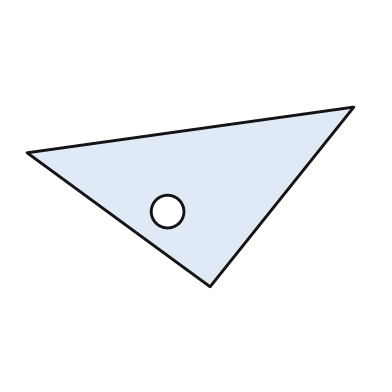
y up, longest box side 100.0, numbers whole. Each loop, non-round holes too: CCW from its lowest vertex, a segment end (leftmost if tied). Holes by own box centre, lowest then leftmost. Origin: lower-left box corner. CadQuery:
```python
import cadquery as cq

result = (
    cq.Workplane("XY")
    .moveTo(56.0, 0.0)
    .lineTo(100.0, 55.0)
    .lineTo(0.0, 41.0)
    .close()
    .moveTo(43.0, 23.0)
    .circle(5.0)
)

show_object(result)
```